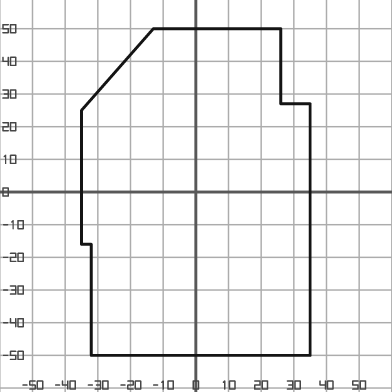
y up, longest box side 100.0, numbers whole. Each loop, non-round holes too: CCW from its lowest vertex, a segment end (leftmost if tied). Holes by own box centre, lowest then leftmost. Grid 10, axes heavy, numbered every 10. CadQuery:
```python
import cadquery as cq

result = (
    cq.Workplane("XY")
    .moveTo(-32.0, -50.0)
    .lineTo(35.0, -50.0)
    .lineTo(35.0, 27.0)
    .lineTo(26.0, 27.0)
    .lineTo(26.0, 50.0)
    .lineTo(-13.0, 50.0)
    .lineTo(-35.0, 25.0)
    .lineTo(-35.0, -16.0)
    .lineTo(-32.0, -16.0)
    .close()
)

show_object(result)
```